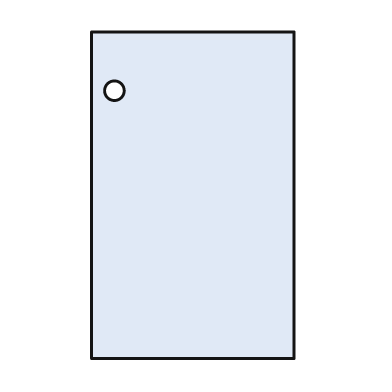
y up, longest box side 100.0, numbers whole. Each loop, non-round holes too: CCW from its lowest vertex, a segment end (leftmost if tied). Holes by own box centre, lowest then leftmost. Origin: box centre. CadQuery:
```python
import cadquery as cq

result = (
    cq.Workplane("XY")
    .moveTo(-31.0, -50.0)
    .lineTo(31.0, -50.0)
    .lineTo(31.0, 50.0)
    .lineTo(-31.0, 50.0)
    .close()
    .moveTo(-24.0, 32.0)
    .circle(3.0)
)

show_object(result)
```